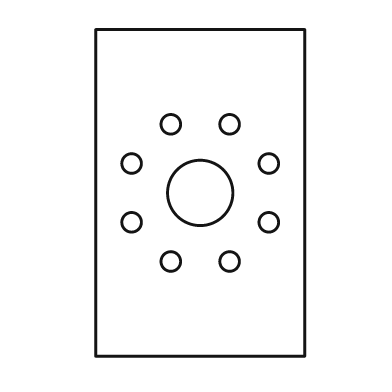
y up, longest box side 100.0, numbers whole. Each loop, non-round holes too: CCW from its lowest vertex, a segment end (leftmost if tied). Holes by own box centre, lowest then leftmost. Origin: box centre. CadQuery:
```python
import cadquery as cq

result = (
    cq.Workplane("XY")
    .moveTo(-32.0, -50.0)
    .lineTo(32.0, -50.0)
    .lineTo(32.0, 50.0)
    .lineTo(-32.0, 50.0)
    .close()
    .moveTo(-9.0, -21.0)
    .circle(3.0)
    .moveTo(9.0, -21.0)
    .circle(3.0)
    .moveTo(-21.0, -9.0)
    .circle(3.0)
    .moveTo(21.0, -9.0)
    .circle(3.0)
    .moveTo(0.0, 0.0)
    .circle(10.0)
    .moveTo(-21.0, 9.0)
    .circle(3.0)
    .moveTo(21.0, 9.0)
    .circle(3.0)
    .moveTo(-9.0, 21.0)
    .circle(3.0)
    .moveTo(9.0, 21.0)
    .circle(3.0)
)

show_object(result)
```